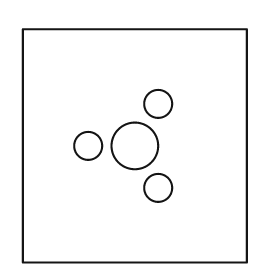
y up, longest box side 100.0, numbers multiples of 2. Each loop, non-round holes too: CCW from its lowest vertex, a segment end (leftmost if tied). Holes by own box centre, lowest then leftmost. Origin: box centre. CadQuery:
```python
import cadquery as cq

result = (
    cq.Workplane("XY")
    .moveTo(-48.0, -50.0)
    .lineTo(48.0, -50.0)
    .lineTo(48.0, 50.0)
    .lineTo(-48.0, 50.0)
    .close()
    .moveTo(10.0, -18.0)
    .circle(6.0)
    .moveTo(-20.0, 0.0)
    .circle(6.0)
    .moveTo(0.0, 0.0)
    .circle(10.0)
    .moveTo(10.0, 18.0)
    .circle(6.0)
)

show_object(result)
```